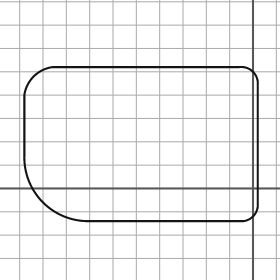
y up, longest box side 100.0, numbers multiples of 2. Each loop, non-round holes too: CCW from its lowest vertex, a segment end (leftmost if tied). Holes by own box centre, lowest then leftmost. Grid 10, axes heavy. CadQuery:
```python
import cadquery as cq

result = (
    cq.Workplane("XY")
    .moveTo(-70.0, -14.0)
    .lineTo(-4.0, -14.0)
    .threePointArc((0.0, -12.0), (2.0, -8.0))
    .lineTo(2.0, 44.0)
    .threePointArc((0.0, 50.0), (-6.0, 52.0))
    .lineTo(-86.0, 52.0)
    .threePointArc((-94.0, 48.0), (-98.0, 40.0))
    .lineTo(-98.0, 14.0)
    .threePointArc((-90.0, -6.0), (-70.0, -14.0))
    .close()
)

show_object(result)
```